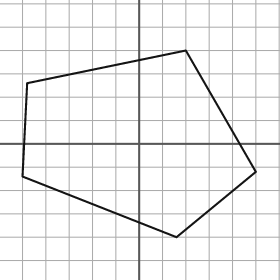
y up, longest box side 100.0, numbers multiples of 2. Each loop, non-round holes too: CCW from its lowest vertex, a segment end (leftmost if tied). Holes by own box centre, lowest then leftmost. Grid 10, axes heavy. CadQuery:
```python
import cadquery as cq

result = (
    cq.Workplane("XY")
    .moveTo(16.0, -40.0)
    .lineTo(50.0, -12.0)
    .lineTo(20.0, 40.0)
    .lineTo(-48.0, 26.0)
    .lineTo(-50.0, -14.0)
    .close()
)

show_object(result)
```